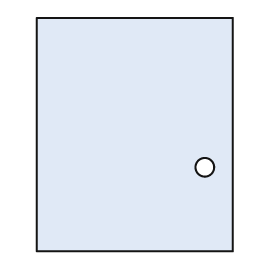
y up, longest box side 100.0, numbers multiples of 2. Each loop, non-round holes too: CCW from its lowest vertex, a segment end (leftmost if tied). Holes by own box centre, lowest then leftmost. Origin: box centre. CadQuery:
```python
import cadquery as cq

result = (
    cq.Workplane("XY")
    .moveTo(-42.0, -50.0)
    .lineTo(42.0, -50.0)
    .lineTo(42.0, 50.0)
    .lineTo(-42.0, 50.0)
    .close()
    .moveTo(30.0, -14.0)
    .circle(4.0)
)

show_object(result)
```